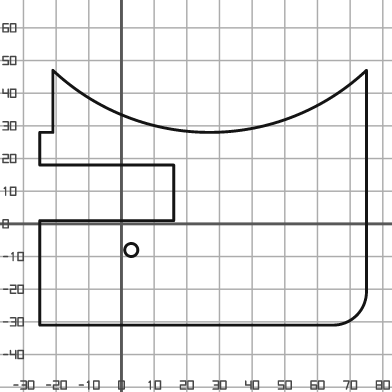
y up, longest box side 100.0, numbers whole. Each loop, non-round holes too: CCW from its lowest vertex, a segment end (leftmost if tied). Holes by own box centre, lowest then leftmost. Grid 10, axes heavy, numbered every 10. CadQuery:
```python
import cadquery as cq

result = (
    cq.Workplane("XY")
    .moveTo(-25.0, -31.0)
    .lineTo(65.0, -31.0)
    .threePointArc((72.0, -28.0), (75.0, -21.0))
    .lineTo(75.0, 47.0)
    .threePointArc((27.0, 28.0), (-21.0, 47.0))
    .lineTo(-21.0, 28.0)
    .lineTo(-25.0, 28.0)
    .lineTo(-25.0, 18.0)
    .lineTo(16.0, 18.0)
    .lineTo(16.0, 1.0)
    .lineTo(-25.0, 1.0)
    .close()
    .moveTo(3.0, -8.0)
    .circle(2.0)
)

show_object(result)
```